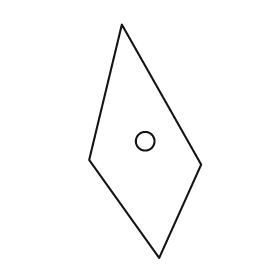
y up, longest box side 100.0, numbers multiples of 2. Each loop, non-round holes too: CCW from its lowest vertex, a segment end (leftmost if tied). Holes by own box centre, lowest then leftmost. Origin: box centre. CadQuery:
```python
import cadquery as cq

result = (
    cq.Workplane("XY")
    .moveTo(6.0, -50.0)
    .lineTo(24.0, -10.0)
    .lineTo(-10.0, 50.0)
    .lineTo(-24.0, -8.0)
    .close()
    .moveTo(0.0, 0.0)
    .circle(4.0)
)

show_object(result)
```